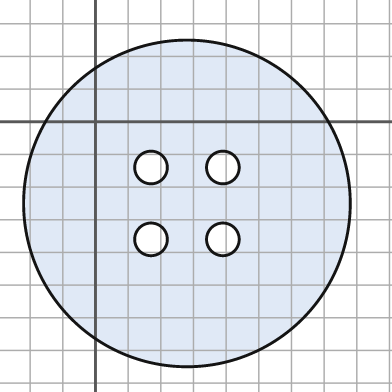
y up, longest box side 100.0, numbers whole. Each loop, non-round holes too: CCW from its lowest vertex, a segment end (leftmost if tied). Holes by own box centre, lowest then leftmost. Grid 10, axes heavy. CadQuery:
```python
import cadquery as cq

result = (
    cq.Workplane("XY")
    .moveTo(28.0, -25.0)
    .circle(50.0)
    .moveTo(17.0, -36.0)
    .circle(5.0)
    .moveTo(39.0, -36.0)
    .circle(5.0)
    .moveTo(17.0, -14.0)
    .circle(5.0)
    .moveTo(39.0, -14.0)
    .circle(5.0)
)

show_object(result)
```